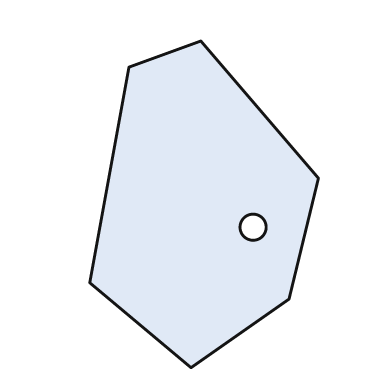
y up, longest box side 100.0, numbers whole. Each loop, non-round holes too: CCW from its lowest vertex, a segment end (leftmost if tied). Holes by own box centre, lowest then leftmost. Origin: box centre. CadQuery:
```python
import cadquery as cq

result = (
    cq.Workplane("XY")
    .moveTo(-4.0, -50.0)
    .lineTo(26.0, -29.0)
    .lineTo(35.0, 8.0)
    .lineTo(-1.0, 50.0)
    .lineTo(-23.0, 42.0)
    .lineTo(-35.0, -24.0)
    .close()
    .moveTo(15.0, -7.0)
    .circle(4.0)
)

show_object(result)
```